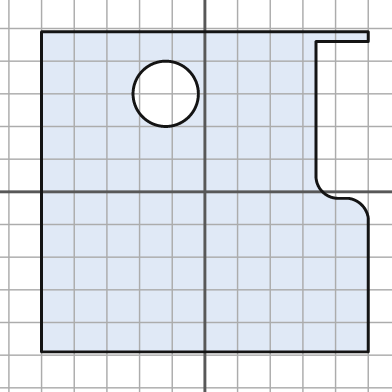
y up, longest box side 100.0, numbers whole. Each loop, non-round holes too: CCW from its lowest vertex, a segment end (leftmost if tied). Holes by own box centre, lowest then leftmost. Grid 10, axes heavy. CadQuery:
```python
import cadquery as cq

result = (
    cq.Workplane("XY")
    .moveTo(-50.0, -49.0)
    .lineTo(50.0, -49.0)
    .lineTo(50.0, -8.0)
    .threePointArc((48.0, -4.0), (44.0, -2.0))
    .lineTo(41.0, -2.0)
    .threePointArc((36.0, 0.0), (34.0, 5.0))
    .lineTo(34.0, 46.0)
    .lineTo(50.0, 46.0)
    .lineTo(50.0, 49.0)
    .lineTo(-50.0, 49.0)
    .close()
    .moveTo(-12.0, 30.0)
    .circle(10.0)
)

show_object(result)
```